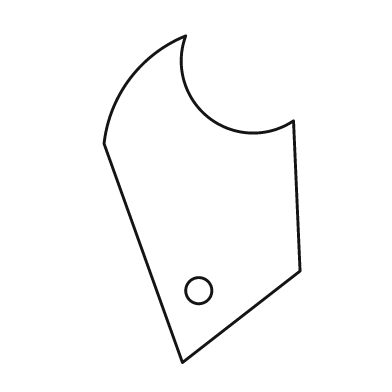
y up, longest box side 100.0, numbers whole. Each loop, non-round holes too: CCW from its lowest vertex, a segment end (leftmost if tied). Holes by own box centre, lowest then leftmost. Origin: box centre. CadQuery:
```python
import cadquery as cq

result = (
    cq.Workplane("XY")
    .moveTo(-6.0, -50.0)
    .lineTo(30.0, -22.0)
    .lineTo(28.0, 24.0)
    .threePointArc((2.0, 25.0), (-5.0, 50.0))
    .threePointArc((-22.0, 37.0), (-30.0, 17.0))
    .close()
    .moveTo(-1.0, -28.0)
    .circle(4.0)
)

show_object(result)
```